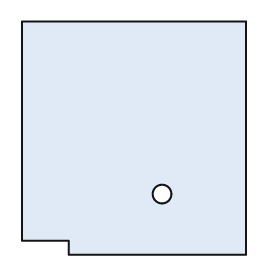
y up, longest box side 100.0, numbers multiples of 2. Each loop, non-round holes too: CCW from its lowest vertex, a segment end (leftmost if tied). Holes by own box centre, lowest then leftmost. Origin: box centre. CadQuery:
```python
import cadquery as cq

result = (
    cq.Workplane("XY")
    .moveTo(-28.0, -50.0)
    .lineTo(48.0, -50.0)
    .lineTo(48.0, 50.0)
    .lineTo(-48.0, 50.0)
    .lineTo(-48.0, -44.0)
    .lineTo(-28.0, -44.0)
    .close()
    .moveTo(12.0, -24.0)
    .circle(4.0)
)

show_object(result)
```